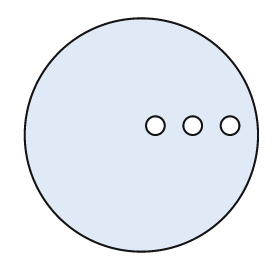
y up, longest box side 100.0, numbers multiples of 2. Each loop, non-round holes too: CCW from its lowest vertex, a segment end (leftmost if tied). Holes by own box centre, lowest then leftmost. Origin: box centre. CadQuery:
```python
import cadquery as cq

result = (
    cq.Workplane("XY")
    .moveTo(0.0, 0.0)
    .circle(50.0)
    .moveTo(6.0, 4.0)
    .circle(4.0)
    .moveTo(22.0, 4.0)
    .circle(4.0)
    .moveTo(38.0, 4.0)
    .circle(4.0)
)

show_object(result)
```